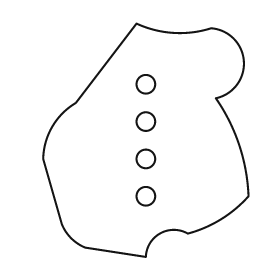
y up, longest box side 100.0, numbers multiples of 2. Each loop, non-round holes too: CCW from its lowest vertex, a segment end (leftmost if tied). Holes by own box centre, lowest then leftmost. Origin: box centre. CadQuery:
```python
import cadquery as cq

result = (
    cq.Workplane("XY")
    .moveTo(0.0, -50.0)
    .threePointArc((6.0, -40.0), (18.0, -40.0))
    .threePointArc((32.0, -34.0), (44.0, -24.0))
    .threePointArc((40.0, -2.0), (30.0, 18.0))
    .threePointArc((42.0, 34.0), (28.0, 48.0))
    .threePointArc((12.0, 46.0), (-4.0, 50.0))
    .lineTo(-30.0, 16.0)
    .threePointArc((-40.0, 6.0), (-44.0, -8.0))
    .lineTo(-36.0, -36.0)
    .threePointArc((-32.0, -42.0), (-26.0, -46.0))
    .close()
    .moveTo(0.0, -24.0)
    .circle(4.0)
    .moveTo(0.0, -8.0)
    .circle(4.0)
    .moveTo(0.0, 8.0)
    .circle(4.0)
    .moveTo(0.0, 24.0)
    .circle(4.0)
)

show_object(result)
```